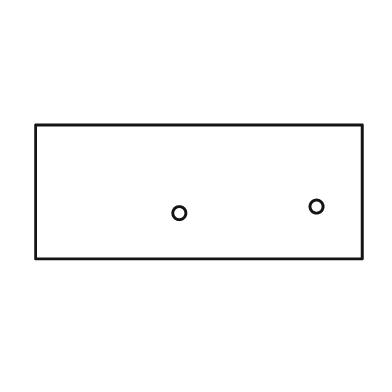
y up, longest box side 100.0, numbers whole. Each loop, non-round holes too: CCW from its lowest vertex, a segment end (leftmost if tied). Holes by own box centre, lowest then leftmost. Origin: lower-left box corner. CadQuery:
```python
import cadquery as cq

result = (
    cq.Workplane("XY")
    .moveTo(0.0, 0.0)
    .lineTo(100.0, 0.0)
    .lineTo(100.0, 41.0)
    .lineTo(0.0, 41.0)
    .close()
    .moveTo(44.0, 14.0)
    .circle(2.0)
    .moveTo(86.0, 16.0)
    .circle(2.0)
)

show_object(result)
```